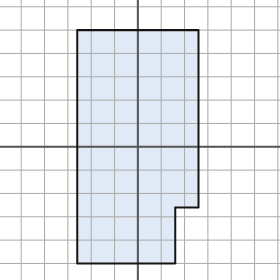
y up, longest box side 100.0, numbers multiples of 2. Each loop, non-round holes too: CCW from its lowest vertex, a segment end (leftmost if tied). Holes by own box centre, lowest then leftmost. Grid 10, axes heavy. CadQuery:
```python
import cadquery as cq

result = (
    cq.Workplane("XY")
    .moveTo(-26.0, -50.0)
    .lineTo(16.0, -50.0)
    .lineTo(16.0, -26.0)
    .lineTo(26.0, -26.0)
    .lineTo(26.0, 50.0)
    .lineTo(-26.0, 50.0)
    .close()
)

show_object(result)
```